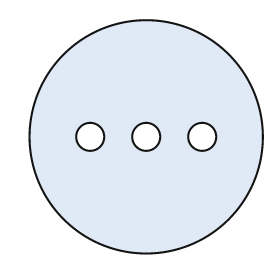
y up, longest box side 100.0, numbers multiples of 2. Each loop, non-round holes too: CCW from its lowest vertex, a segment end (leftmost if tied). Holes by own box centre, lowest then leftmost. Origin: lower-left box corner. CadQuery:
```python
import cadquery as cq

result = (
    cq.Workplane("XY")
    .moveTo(50.0, 50.0)
    .circle(50.0)
    .moveTo(26.0, 50.0)
    .circle(6.0)
    .moveTo(50.0, 50.0)
    .circle(6.0)
    .moveTo(74.0, 50.0)
    .circle(6.0)
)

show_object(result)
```